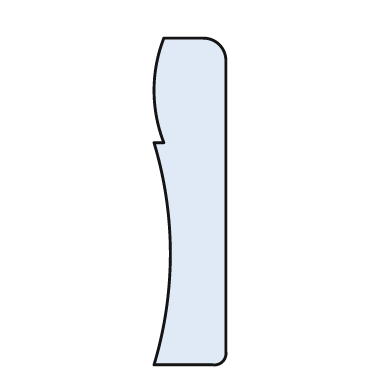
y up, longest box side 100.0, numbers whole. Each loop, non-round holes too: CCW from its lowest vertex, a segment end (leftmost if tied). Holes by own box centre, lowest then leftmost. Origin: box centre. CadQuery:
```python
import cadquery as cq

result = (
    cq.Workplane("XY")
    .moveTo(-11.0, -50.0)
    .lineTo(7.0, -50.0)
    .threePointArc((10.0, -49.0), (11.0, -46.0))
    .lineTo(11.0, 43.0)
    .threePointArc((9.0, 48.0), (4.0, 50.0))
    .lineTo(-8.0, 50.0)
    .threePointArc((-11.0, 34.0), (-8.0, 18.0))
    .lineTo(-11.0, 18.0)
    .threePointArc((-6.0, -16.0), (-11.0, -50.0))
    .close()
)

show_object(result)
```